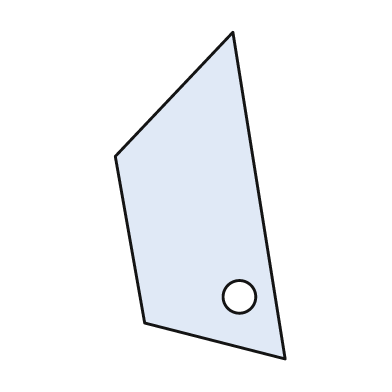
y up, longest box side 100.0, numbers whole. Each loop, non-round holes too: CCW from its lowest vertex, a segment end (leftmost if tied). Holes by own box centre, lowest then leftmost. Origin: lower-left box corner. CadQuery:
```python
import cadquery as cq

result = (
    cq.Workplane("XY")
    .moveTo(52.0, 0.0)
    .lineTo(36.0, 100.0)
    .lineTo(0.0, 62.0)
    .lineTo(9.0, 11.0)
    .close()
    .moveTo(38.0, 19.0)
    .circle(5.0)
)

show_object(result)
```